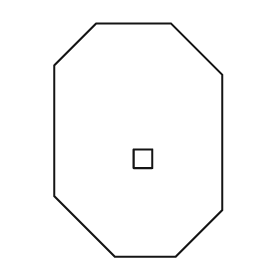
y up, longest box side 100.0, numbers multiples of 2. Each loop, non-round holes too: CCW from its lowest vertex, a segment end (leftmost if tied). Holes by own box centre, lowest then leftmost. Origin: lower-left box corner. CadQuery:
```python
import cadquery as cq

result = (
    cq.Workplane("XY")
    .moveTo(26.0, 0.0)
    .lineTo(52.0, 0.0)
    .lineTo(72.0, 20.0)
    .lineTo(72.0, 78.0)
    .lineTo(50.0, 100.0)
    .lineTo(18.0, 100.0)
    .lineTo(0.0, 82.0)
    .lineTo(0.0, 26.0)
    .close()
    .moveTo(34.0, 38.0)
    .lineTo(42.0, 38.0)
    .lineTo(42.0, 46.0)
    .lineTo(34.0, 46.0)
    .close()
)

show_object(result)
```